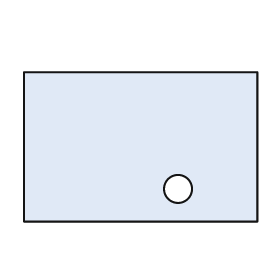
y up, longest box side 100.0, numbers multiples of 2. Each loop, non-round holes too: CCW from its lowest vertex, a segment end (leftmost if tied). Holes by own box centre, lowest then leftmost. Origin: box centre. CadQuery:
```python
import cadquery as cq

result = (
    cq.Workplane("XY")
    .moveTo(-50.0, -32.0)
    .lineTo(50.0, -32.0)
    .lineTo(50.0, 32.0)
    .lineTo(-50.0, 32.0)
    .close()
    .moveTo(16.0, -18.0)
    .circle(6.0)
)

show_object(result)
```